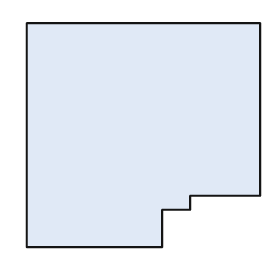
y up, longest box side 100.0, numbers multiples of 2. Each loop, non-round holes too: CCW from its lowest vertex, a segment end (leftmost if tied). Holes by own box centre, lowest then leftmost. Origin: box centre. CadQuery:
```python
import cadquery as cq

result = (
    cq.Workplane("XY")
    .moveTo(-50.0, -48.0)
    .lineTo(8.0, -48.0)
    .lineTo(8.0, -32.0)
    .lineTo(20.0, -32.0)
    .lineTo(20.0, -26.0)
    .lineTo(50.0, -26.0)
    .lineTo(50.0, 48.0)
    .lineTo(-50.0, 48.0)
    .close()
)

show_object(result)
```